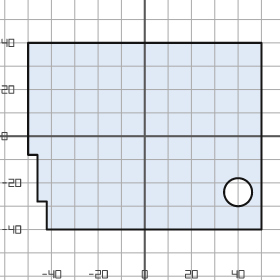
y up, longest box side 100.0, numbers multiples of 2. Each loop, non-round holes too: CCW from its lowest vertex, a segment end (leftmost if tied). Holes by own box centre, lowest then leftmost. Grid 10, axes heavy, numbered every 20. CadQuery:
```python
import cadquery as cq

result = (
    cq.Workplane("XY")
    .moveTo(-42.0, -40.0)
    .lineTo(50.0, -40.0)
    .lineTo(50.0, 40.0)
    .lineTo(-50.0, 40.0)
    .lineTo(-50.0, -8.0)
    .lineTo(-46.0, -8.0)
    .lineTo(-46.0, -28.0)
    .lineTo(-42.0, -28.0)
    .close()
    .moveTo(40.0, -24.0)
    .circle(6.0)
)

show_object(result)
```